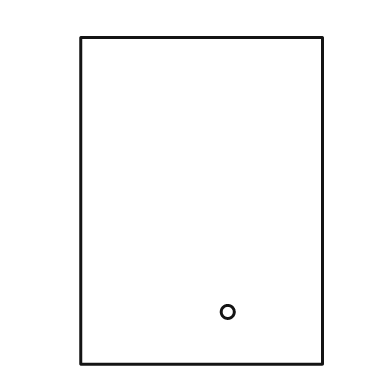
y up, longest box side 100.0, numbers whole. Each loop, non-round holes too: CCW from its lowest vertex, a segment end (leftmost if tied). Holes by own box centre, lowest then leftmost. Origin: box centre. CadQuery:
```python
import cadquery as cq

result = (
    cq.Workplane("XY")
    .moveTo(-37.0, -50.0)
    .lineTo(37.0, -50.0)
    .lineTo(37.0, 50.0)
    .lineTo(-37.0, 50.0)
    .close()
    .moveTo(8.0, -34.0)
    .circle(2.0)
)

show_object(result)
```